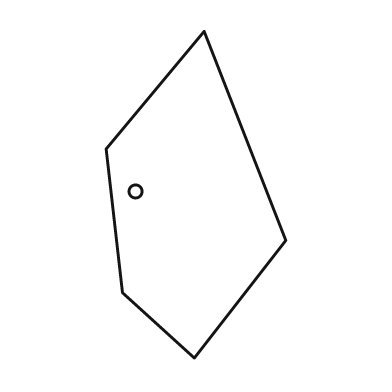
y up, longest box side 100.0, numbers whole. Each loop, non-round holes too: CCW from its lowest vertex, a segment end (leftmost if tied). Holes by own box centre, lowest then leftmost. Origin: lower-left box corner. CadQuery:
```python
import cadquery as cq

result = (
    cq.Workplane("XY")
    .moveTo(27.0, 0.0)
    .lineTo(55.0, 36.0)
    .lineTo(30.0, 100.0)
    .lineTo(0.0, 64.0)
    .lineTo(5.0, 20.0)
    .close()
    .moveTo(9.0, 51.0)
    .circle(2.0)
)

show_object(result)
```